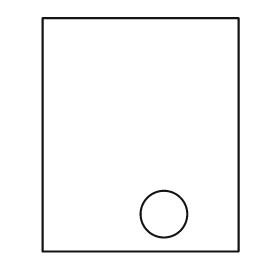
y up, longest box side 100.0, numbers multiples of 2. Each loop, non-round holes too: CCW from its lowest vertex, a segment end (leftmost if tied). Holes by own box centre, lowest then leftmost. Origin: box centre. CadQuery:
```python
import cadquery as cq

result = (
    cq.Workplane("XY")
    .moveTo(-42.0, -50.0)
    .lineTo(42.0, -50.0)
    .lineTo(42.0, 50.0)
    .lineTo(-42.0, 50.0)
    .close()
    .moveTo(10.0, -34.0)
    .circle(10.0)
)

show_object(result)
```